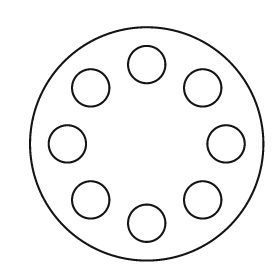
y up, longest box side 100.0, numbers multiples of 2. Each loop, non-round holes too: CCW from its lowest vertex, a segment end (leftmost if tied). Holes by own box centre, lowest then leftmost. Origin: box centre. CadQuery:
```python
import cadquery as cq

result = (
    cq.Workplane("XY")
    .moveTo(0.0, 0.0)
    .circle(50.0)
    .moveTo(0.0, -34.0)
    .circle(8.0)
    .moveTo(-24.0, -24.0)
    .circle(8.0)
    .moveTo(24.0, -24.0)
    .circle(8.0)
    .moveTo(-34.0, 0.0)
    .circle(8.0)
    .moveTo(34.0, 0.0)
    .circle(8.0)
    .moveTo(-24.0, 24.0)
    .circle(8.0)
    .moveTo(24.0, 24.0)
    .circle(8.0)
    .moveTo(0.0, 34.0)
    .circle(8.0)
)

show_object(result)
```